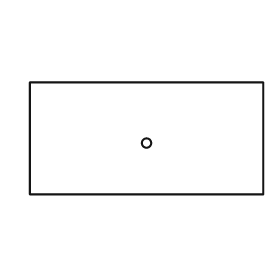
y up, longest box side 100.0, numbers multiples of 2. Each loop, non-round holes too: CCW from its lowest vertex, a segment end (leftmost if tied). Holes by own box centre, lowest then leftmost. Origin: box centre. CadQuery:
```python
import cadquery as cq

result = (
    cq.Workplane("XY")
    .moveTo(-50.0, -24.0)
    .lineTo(50.0, -24.0)
    .lineTo(50.0, 24.0)
    .lineTo(-50.0, 24.0)
    .close()
    .moveTo(0.0, -2.0)
    .circle(2.0)
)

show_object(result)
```